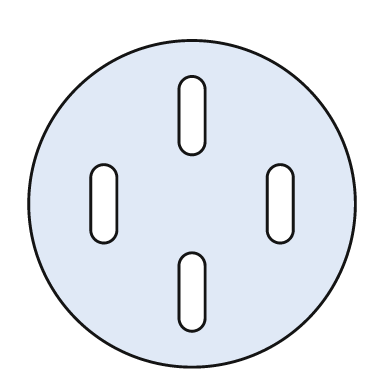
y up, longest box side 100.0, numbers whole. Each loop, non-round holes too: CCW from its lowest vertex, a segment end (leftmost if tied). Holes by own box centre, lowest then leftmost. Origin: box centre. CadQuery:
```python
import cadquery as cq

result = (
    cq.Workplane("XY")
    .moveTo(0.0, 0.0)
    .circle(50.0)
    .moveTo(-4.0, -35.0)
    .threePointArc((0.0, -39.0), (4.0, -35.0))
    .lineTo(4.0, -19.0)
    .threePointArc((0.0, -15.0), (-4.0, -19.0))
    .close()
    .moveTo(-31.0, -8.0)
    .threePointArc((-27.0, -12.0), (-23.0, -8.0))
    .lineTo(-23.0, 8.0)
    .threePointArc((-27.0, 12.0), (-31.0, 8.0))
    .close()
    .moveTo(23.0, -8.0)
    .threePointArc((27.0, -12.0), (31.0, -8.0))
    .lineTo(31.0, 8.0)
    .threePointArc((27.0, 12.0), (23.0, 8.0))
    .close()
    .moveTo(-4.0, 19.0)
    .threePointArc((0.0, 15.0), (4.0, 19.0))
    .lineTo(4.0, 35.0)
    .threePointArc((0.0, 39.0), (-4.0, 35.0))
    .close()
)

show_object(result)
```